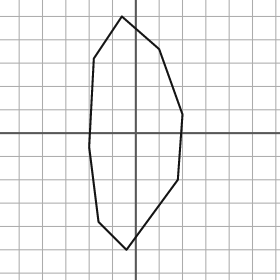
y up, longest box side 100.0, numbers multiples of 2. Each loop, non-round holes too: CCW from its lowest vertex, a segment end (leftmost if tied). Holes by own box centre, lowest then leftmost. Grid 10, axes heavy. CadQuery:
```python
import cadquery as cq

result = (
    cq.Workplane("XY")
    .moveTo(-4.0, -50.0)
    .lineTo(18.0, -20.0)
    .lineTo(20.0, 8.0)
    .lineTo(10.0, 36.0)
    .lineTo(-6.0, 50.0)
    .lineTo(-18.0, 32.0)
    .lineTo(-20.0, -6.0)
    .lineTo(-16.0, -38.0)
    .close()
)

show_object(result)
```